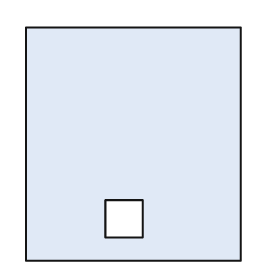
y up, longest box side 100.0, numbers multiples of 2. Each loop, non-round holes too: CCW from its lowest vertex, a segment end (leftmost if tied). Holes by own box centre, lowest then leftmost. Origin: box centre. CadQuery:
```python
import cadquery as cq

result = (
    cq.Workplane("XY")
    .moveTo(-46.0, -50.0)
    .lineTo(46.0, -50.0)
    .lineTo(46.0, 50.0)
    .lineTo(-46.0, 50.0)
    .close()
    .moveTo(-12.0, -40.0)
    .lineTo(4.0, -40.0)
    .lineTo(4.0, -24.0)
    .lineTo(-12.0, -24.0)
    .close()
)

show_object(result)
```